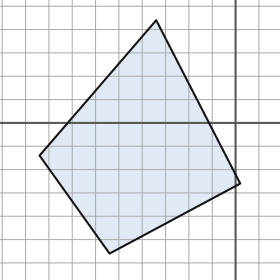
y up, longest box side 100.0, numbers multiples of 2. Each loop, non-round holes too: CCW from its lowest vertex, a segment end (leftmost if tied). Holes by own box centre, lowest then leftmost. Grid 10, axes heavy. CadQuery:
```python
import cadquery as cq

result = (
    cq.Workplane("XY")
    .moveTo(-54.0, -56.0)
    .lineTo(2.0, -26.0)
    .lineTo(-34.0, 44.0)
    .lineTo(-84.0, -14.0)
    .close()
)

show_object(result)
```